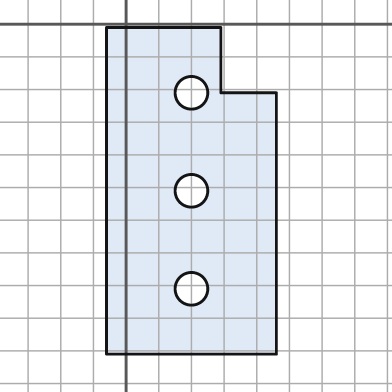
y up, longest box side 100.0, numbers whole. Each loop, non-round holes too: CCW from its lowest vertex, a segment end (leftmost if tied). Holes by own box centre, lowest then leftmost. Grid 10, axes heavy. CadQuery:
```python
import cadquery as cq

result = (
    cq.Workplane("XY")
    .moveTo(-6.0, -101.0)
    .lineTo(46.0, -101.0)
    .lineTo(46.0, -21.0)
    .lineTo(29.0, -21.0)
    .lineTo(29.0, -1.0)
    .lineTo(-6.0, -1.0)
    .close()
    .moveTo(20.0, -81.0)
    .circle(5.0)
    .moveTo(20.0, -51.0)
    .circle(5.0)
    .moveTo(20.0, -21.0)
    .circle(5.0)
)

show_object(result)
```